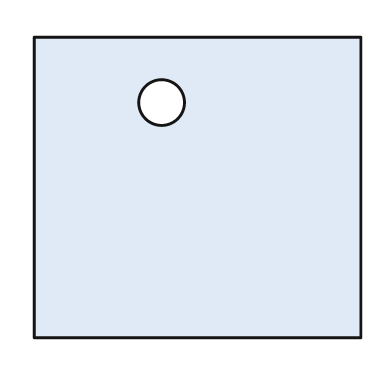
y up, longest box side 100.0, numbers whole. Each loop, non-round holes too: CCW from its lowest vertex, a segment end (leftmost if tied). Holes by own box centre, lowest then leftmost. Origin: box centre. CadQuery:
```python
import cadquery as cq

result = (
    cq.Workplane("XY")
    .moveTo(-50.0, -46.0)
    .lineTo(50.0, -46.0)
    .lineTo(50.0, 46.0)
    .lineTo(-50.0, 46.0)
    .close()
    .moveTo(-11.0, 26.0)
    .circle(7.0)
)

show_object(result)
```